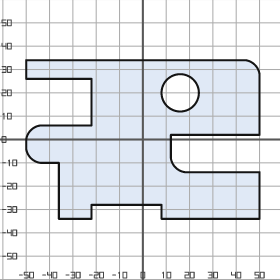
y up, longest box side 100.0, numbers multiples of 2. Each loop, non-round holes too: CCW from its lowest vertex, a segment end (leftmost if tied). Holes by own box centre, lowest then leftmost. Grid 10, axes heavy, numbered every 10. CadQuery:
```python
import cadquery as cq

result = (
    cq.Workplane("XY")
    .moveTo(-36.0, -34.0)
    .lineTo(-22.0, -34.0)
    .lineTo(-22.0, -28.0)
    .lineTo(8.0, -28.0)
    .lineTo(8.0, -34.0)
    .lineTo(50.0, -34.0)
    .lineTo(50.0, -14.0)
    .lineTo(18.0, -14.0)
    .threePointArc((14.0, -12.0), (12.0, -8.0))
    .lineTo(12.0, 2.0)
    .lineTo(50.0, 2.0)
    .lineTo(50.0, 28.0)
    .threePointArc((48.0, 32.0), (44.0, 34.0))
    .lineTo(-50.0, 34.0)
    .lineTo(-50.0, 26.0)
    .lineTo(-22.0, 26.0)
    .lineTo(-22.0, 6.0)
    .lineTo(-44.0, 6.0)
    .threePointArc((-48.0, 4.0), (-50.0, 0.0))
    .lineTo(-50.0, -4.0)
    .threePointArc((-48.0, -8.0), (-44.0, -10.0))
    .lineTo(-36.0, -10.0)
    .close()
    .moveTo(16.0, 20.0)
    .circle(8.0)
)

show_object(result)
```